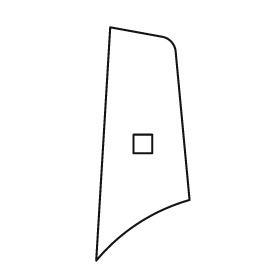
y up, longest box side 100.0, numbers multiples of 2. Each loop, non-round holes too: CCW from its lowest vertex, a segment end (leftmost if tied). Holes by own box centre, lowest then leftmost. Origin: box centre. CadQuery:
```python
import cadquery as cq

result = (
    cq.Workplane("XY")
    .moveTo(-20.0, -50.0)
    .threePointArc((-2.0, -34.0), (20.0, -24.0))
    .lineTo(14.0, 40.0)
    .threePointArc((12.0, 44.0), (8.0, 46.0))
    .lineTo(-14.0, 50.0)
    .close()
    .moveTo(-4.0, -4.0)
    .lineTo(4.0, -4.0)
    .lineTo(4.0, 4.0)
    .lineTo(-4.0, 4.0)
    .close()
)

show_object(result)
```